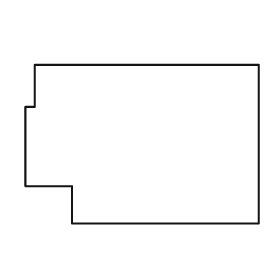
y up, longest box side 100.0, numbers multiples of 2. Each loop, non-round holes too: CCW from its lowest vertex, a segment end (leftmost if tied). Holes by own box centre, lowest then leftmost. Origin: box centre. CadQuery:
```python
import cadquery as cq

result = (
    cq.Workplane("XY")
    .moveTo(-30.0, -34.0)
    .lineTo(50.0, -34.0)
    .lineTo(50.0, 34.0)
    .lineTo(-46.0, 34.0)
    .lineTo(-46.0, 16.0)
    .lineTo(-50.0, 16.0)
    .lineTo(-50.0, -18.0)
    .lineTo(-30.0, -18.0)
    .close()
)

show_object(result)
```